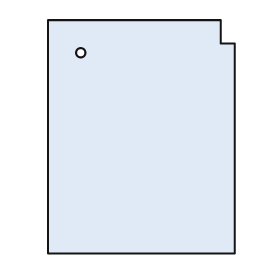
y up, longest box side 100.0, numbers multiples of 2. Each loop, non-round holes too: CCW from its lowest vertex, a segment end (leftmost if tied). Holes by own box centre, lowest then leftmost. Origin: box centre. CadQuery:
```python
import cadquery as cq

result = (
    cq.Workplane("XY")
    .moveTo(-40.0, -50.0)
    .lineTo(40.0, -50.0)
    .lineTo(40.0, 40.0)
    .lineTo(34.0, 40.0)
    .lineTo(34.0, 50.0)
    .lineTo(-40.0, 50.0)
    .close()
    .moveTo(-26.0, 36.0)
    .circle(2.0)
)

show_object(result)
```